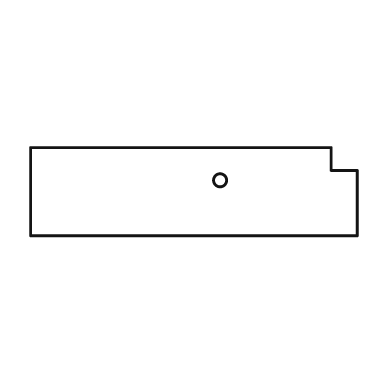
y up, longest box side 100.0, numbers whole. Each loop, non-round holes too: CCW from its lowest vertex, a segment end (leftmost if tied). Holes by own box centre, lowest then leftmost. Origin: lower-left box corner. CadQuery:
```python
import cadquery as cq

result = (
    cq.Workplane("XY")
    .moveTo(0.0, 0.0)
    .lineTo(100.0, 0.0)
    .lineTo(100.0, 20.0)
    .lineTo(92.0, 20.0)
    .lineTo(92.0, 27.0)
    .lineTo(0.0, 27.0)
    .close()
    .moveTo(58.0, 17.0)
    .circle(2.0)
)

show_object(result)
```